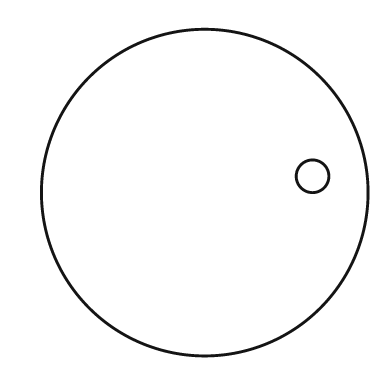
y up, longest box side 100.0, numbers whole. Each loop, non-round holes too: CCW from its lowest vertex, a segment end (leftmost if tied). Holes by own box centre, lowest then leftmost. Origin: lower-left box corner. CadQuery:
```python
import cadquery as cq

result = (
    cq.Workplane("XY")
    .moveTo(50.0, 50.0)
    .circle(50.0)
    .moveTo(83.0, 55.0)
    .circle(5.0)
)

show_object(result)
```